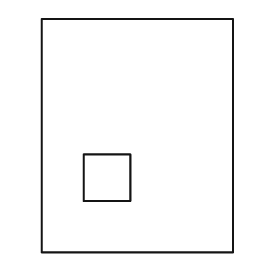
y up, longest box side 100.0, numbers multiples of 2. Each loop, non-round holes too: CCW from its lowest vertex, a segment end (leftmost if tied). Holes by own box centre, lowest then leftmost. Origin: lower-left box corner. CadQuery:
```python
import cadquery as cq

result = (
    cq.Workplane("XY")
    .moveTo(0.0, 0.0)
    .lineTo(82.0, 0.0)
    .lineTo(82.0, 100.0)
    .lineTo(0.0, 100.0)
    .close()
    .moveTo(18.0, 22.0)
    .lineTo(38.0, 22.0)
    .lineTo(38.0, 42.0)
    .lineTo(18.0, 42.0)
    .close()
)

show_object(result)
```